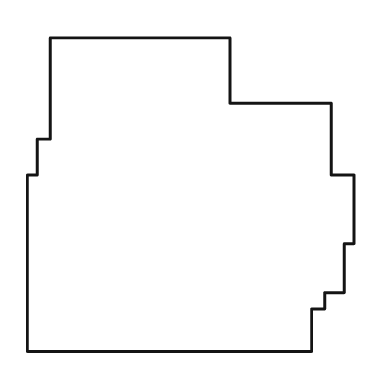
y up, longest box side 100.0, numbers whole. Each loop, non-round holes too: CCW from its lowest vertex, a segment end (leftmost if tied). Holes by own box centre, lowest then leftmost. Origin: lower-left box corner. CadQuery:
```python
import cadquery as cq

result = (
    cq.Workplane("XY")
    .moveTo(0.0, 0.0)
    .lineTo(87.0, 0.0)
    .lineTo(87.0, 13.0)
    .lineTo(91.0, 13.0)
    .lineTo(91.0, 18.0)
    .lineTo(97.0, 18.0)
    .lineTo(97.0, 33.0)
    .lineTo(100.0, 33.0)
    .lineTo(100.0, 54.0)
    .lineTo(93.0, 54.0)
    .lineTo(93.0, 76.0)
    .lineTo(62.0, 76.0)
    .lineTo(62.0, 96.0)
    .lineTo(7.0, 96.0)
    .lineTo(7.0, 65.0)
    .lineTo(3.0, 65.0)
    .lineTo(3.0, 54.0)
    .lineTo(0.0, 54.0)
    .close()
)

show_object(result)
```